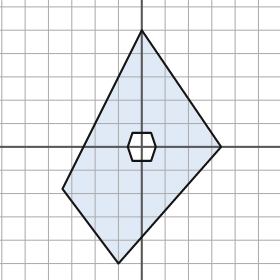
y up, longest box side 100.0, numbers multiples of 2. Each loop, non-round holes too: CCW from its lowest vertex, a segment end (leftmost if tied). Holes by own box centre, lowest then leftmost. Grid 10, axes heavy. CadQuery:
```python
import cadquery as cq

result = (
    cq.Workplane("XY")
    .moveTo(-10.0, -50.0)
    .lineTo(34.0, 0.0)
    .lineTo(0.0, 50.0)
    .lineTo(-34.0, -18.0)
    .close()
    .moveTo(-4.0, -6.0)
    .lineTo(4.0, -6.0)
    .lineTo(6.0, 0.0)
    .lineTo(4.0, 6.0)
    .lineTo(-4.0, 6.0)
    .lineTo(-6.0, 0.0)
    .close()
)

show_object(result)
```